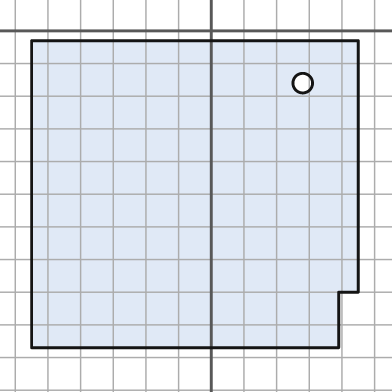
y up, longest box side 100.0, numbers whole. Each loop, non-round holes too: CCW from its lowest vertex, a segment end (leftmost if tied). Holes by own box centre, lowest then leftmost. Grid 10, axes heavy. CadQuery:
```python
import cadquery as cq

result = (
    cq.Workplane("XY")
    .moveTo(-55.0, -97.0)
    .lineTo(39.0, -97.0)
    .lineTo(39.0, -80.0)
    .lineTo(45.0, -80.0)
    .lineTo(45.0, -3.0)
    .lineTo(-55.0, -3.0)
    .close()
    .moveTo(28.0, -16.0)
    .circle(3.0)
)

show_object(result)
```